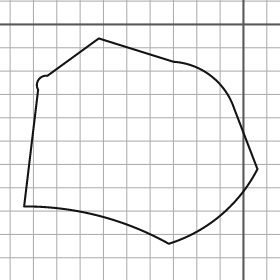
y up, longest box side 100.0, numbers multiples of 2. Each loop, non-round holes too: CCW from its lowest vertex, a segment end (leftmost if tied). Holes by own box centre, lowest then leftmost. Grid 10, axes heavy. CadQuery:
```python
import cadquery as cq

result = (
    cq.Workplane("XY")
    .moveTo(-32.0, -94.0)
    .threePointArc((-10.0, -82.0), (6.0, -62.0))
    .lineTo(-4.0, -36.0)
    .threePointArc((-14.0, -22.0), (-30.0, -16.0))
    .lineTo(-62.0, -6.0)
    .lineTo(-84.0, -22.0)
    .threePointArc((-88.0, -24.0), (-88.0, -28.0))
    .lineTo(-94.0, -78.0)
    .threePointArc((-62.0, -82.0), (-32.0, -94.0))
    .close()
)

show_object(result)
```